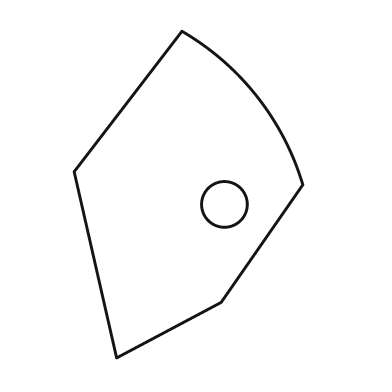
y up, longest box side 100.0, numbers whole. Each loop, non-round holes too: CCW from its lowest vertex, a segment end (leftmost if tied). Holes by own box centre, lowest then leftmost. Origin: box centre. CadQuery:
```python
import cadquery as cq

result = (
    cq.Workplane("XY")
    .moveTo(-22.0, -50.0)
    .lineTo(10.0, -33.0)
    .lineTo(35.0, 3.0)
    .threePointArc((21.0, 30.0), (-2.0, 50.0))
    .lineTo(-35.0, 7.0)
    .close()
    .moveTo(11.0, -3.0)
    .circle(7.0)
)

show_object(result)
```